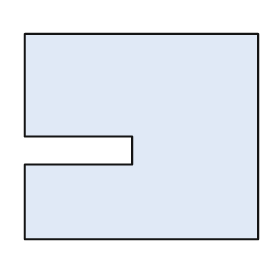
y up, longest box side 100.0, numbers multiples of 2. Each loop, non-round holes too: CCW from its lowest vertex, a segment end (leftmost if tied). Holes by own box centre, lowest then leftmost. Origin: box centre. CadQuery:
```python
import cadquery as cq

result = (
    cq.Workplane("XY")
    .moveTo(-50.0, -44.0)
    .lineTo(50.0, -44.0)
    .lineTo(50.0, 44.0)
    .lineTo(-50.0, 44.0)
    .lineTo(-50.0, 0.0)
    .lineTo(-4.0, 0.0)
    .lineTo(-4.0, -12.0)
    .lineTo(-50.0, -12.0)
    .close()
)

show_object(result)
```